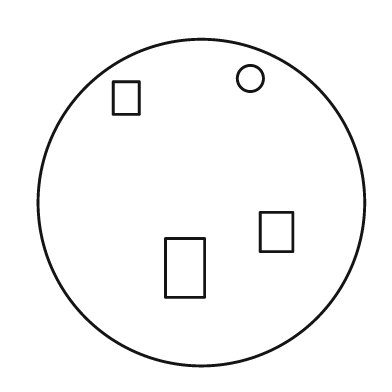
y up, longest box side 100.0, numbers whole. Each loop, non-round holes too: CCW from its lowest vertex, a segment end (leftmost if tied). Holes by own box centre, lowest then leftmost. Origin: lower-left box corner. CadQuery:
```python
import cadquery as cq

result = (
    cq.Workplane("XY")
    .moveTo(50.0, 50.0)
    .circle(50.0)
    .moveTo(39.0, 21.0)
    .lineTo(51.0, 21.0)
    .lineTo(51.0, 39.0)
    .lineTo(39.0, 39.0)
    .close()
    .moveTo(68.0, 35.0)
    .lineTo(78.0, 35.0)
    .lineTo(78.0, 47.0)
    .lineTo(68.0, 47.0)
    .close()
    .moveTo(23.0, 77.0)
    .lineTo(31.0, 77.0)
    .lineTo(31.0, 87.0)
    .lineTo(23.0, 87.0)
    .close()
    .moveTo(65.0, 88.0)
    .circle(4.0)
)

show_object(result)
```